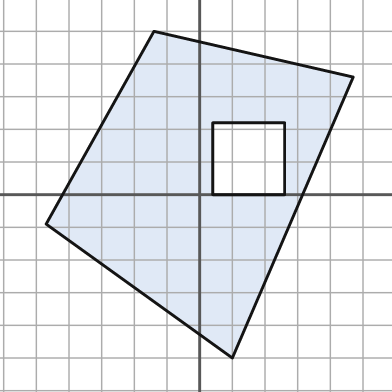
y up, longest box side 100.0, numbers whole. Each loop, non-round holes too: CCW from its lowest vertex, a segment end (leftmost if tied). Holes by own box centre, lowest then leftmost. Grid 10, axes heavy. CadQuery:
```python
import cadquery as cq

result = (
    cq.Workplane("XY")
    .moveTo(10.0, -50.0)
    .lineTo(47.0, 36.0)
    .lineTo(-14.0, 50.0)
    .lineTo(-47.0, -9.0)
    .close()
    .moveTo(4.0, 0.0)
    .lineTo(26.0, 0.0)
    .lineTo(26.0, 22.0)
    .lineTo(4.0, 22.0)
    .close()
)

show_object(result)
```